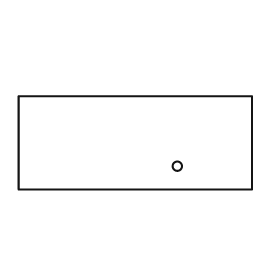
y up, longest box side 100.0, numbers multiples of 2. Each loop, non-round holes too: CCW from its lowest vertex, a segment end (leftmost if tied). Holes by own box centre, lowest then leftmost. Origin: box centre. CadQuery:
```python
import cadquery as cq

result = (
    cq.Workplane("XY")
    .moveTo(-50.0, -20.0)
    .lineTo(50.0, -20.0)
    .lineTo(50.0, 20.0)
    .lineTo(-50.0, 20.0)
    .close()
    .moveTo(18.0, -10.0)
    .circle(2.0)
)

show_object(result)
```